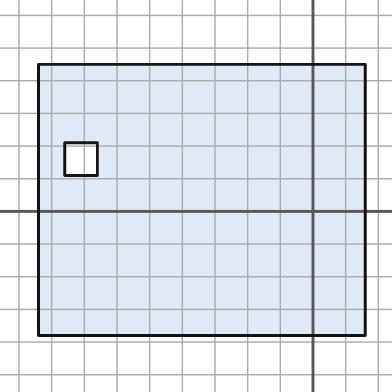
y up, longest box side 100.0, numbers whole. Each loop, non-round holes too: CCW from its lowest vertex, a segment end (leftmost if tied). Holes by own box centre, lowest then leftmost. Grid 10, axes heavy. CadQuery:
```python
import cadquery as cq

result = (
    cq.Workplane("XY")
    .moveTo(-84.0, -38.0)
    .lineTo(16.0, -38.0)
    .lineTo(16.0, 45.0)
    .lineTo(-84.0, 45.0)
    .close()
    .moveTo(-76.0, 11.0)
    .lineTo(-66.0, 11.0)
    .lineTo(-66.0, 21.0)
    .lineTo(-76.0, 21.0)
    .close()
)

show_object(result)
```